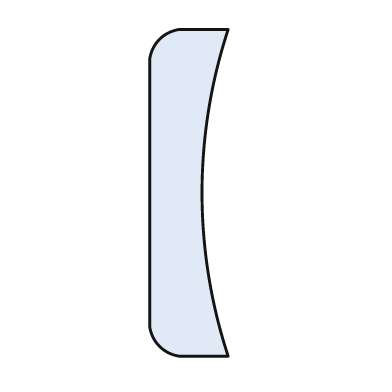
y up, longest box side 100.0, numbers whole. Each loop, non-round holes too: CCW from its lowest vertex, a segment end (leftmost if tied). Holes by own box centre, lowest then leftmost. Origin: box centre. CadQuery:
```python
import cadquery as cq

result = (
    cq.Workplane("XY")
    .moveTo(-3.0, -50.0)
    .lineTo(12.0, -50.0)
    .threePointArc((4.0, 0.0), (12.0, 50.0))
    .lineTo(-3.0, 50.0)
    .threePointArc((-9.0, 47.0), (-12.0, 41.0))
    .lineTo(-12.0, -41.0)
    .threePointArc((-9.0, -47.0), (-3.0, -50.0))
    .close()
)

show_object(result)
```